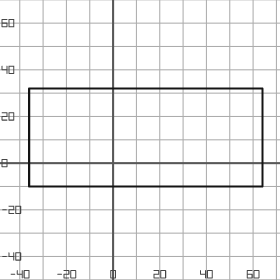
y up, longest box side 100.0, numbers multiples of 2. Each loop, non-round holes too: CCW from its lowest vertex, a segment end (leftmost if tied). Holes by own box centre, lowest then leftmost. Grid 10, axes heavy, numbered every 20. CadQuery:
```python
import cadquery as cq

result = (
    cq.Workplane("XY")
    .moveTo(-36.0, -10.0)
    .lineTo(64.0, -10.0)
    .lineTo(64.0, 32.0)
    .lineTo(-36.0, 32.0)
    .close()
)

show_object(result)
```